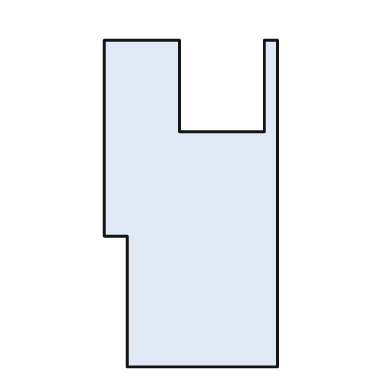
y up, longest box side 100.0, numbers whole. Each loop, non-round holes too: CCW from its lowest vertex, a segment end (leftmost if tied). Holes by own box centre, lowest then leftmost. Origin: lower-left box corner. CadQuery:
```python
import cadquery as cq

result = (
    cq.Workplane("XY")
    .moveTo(7.0, 0.0)
    .lineTo(53.0, 0.0)
    .lineTo(53.0, 100.0)
    .lineTo(49.0, 100.0)
    .lineTo(49.0, 72.0)
    .lineTo(23.0, 72.0)
    .lineTo(23.0, 100.0)
    .lineTo(0.0, 100.0)
    .lineTo(0.0, 40.0)
    .lineTo(7.0, 40.0)
    .close()
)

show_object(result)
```